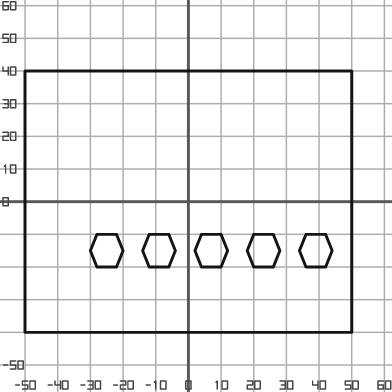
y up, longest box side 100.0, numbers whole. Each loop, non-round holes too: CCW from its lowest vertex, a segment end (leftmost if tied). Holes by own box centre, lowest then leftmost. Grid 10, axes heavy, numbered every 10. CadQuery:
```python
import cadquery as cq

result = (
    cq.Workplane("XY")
    .moveTo(-50.0, -40.0)
    .lineTo(50.0, -40.0)
    .lineTo(50.0, 40.0)
    .lineTo(-50.0, 40.0)
    .close()
    .moveTo(-28.0, -20.0)
    .lineTo(-22.0, -20.0)
    .lineTo(-20.0, -15.0)
    .lineTo(-22.0, -10.0)
    .lineTo(-28.0, -10.0)
    .lineTo(-30.0, -15.0)
    .close()
    .moveTo(-12.0, -20.0)
    .lineTo(-6.0, -20.0)
    .lineTo(-4.0, -15.0)
    .lineTo(-6.0, -10.0)
    .lineTo(-12.0, -10.0)
    .lineTo(-14.0, -15.0)
    .close()
    .moveTo(4.0, -20.0)
    .lineTo(10.0, -20.0)
    .lineTo(12.0, -15.0)
    .lineTo(10.0, -10.0)
    .lineTo(4.0, -10.0)
    .lineTo(2.0, -15.0)
    .close()
    .moveTo(20.0, -20.0)
    .lineTo(26.0, -20.0)
    .lineTo(28.0, -15.0)
    .lineTo(26.0, -10.0)
    .lineTo(20.0, -10.0)
    .lineTo(18.0, -15.0)
    .close()
    .moveTo(36.0, -20.0)
    .lineTo(42.0, -20.0)
    .lineTo(44.0, -15.0)
    .lineTo(42.0, -10.0)
    .lineTo(36.0, -10.0)
    .lineTo(34.0, -15.0)
    .close()
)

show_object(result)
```